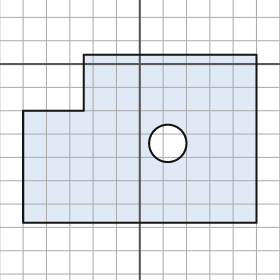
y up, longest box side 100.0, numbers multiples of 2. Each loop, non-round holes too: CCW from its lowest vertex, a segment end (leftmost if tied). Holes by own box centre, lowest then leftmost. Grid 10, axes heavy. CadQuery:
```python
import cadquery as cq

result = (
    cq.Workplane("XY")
    .moveTo(-50.0, -68.0)
    .lineTo(50.0, -68.0)
    .lineTo(50.0, 4.0)
    .lineTo(-24.0, 4.0)
    .lineTo(-24.0, -20.0)
    .lineTo(-50.0, -20.0)
    .close()
    .moveTo(12.0, -34.0)
    .circle(8.0)
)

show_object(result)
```